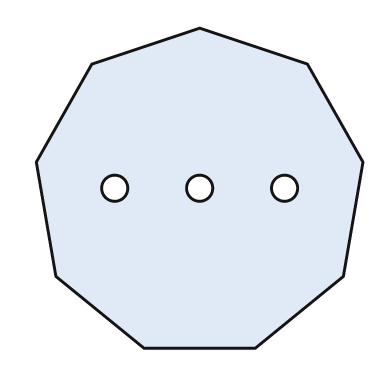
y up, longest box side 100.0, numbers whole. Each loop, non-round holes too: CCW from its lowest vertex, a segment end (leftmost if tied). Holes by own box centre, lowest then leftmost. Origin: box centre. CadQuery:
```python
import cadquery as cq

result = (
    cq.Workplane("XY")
    .moveTo(-17.0, -49.0)
    .lineTo(17.0, -49.0)
    .lineTo(44.0, -27.0)
    .lineTo(50.0, 8.0)
    .lineTo(33.0, 38.0)
    .lineTo(0.0, 49.0)
    .lineTo(-33.0, 38.0)
    .lineTo(-50.0, 8.0)
    .lineTo(-44.0, -27.0)
    .close()
    .moveTo(-26.0, 0.0)
    .circle(4.0)
    .moveTo(0.0, 0.0)
    .circle(4.0)
    .moveTo(26.0, 0.0)
    .circle(4.0)
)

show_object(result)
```